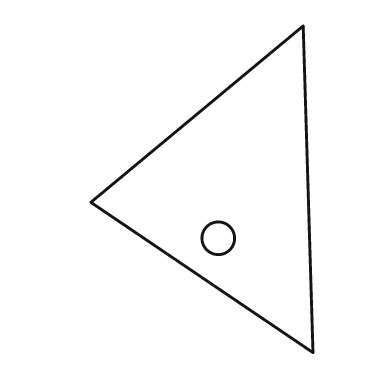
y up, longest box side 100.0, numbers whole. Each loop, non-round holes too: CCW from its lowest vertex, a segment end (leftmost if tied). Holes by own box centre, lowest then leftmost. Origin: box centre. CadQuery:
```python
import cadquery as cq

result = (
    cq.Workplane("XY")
    .moveTo(34.0, -50.0)
    .lineTo(31.0, 50.0)
    .lineTo(-34.0, -4.0)
    .close()
    .moveTo(5.0, -15.0)
    .circle(5.0)
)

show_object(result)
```